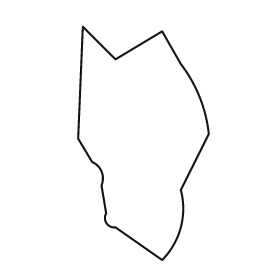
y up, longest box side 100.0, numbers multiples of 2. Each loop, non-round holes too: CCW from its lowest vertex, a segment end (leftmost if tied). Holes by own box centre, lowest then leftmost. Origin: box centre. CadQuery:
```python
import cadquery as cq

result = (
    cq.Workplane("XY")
    .moveTo(8.0, -50.0)
    .threePointArc((16.0, -36.0), (16.0, -20.0))
    .lineTo(28.0, 4.0)
    .threePointArc((24.0, 20.0), (16.0, 34.0))
    .lineTo(8.0, 48.0)
    .lineTo(-12.0, 36.0)
    .lineTo(-26.0, 50.0)
    .lineTo(-28.0, 2.0)
    .lineTo(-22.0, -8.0)
    .threePointArc((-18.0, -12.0), (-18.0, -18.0))
    .lineTo(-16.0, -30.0)
    .threePointArc((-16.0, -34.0), (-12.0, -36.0))
    .close()
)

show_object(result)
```